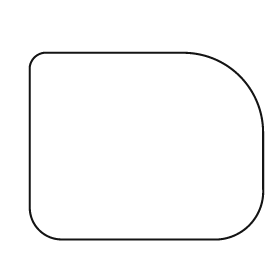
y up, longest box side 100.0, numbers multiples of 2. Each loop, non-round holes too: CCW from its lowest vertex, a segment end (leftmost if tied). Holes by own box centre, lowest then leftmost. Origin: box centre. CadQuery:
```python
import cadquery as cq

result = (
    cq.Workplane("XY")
    .moveTo(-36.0, -40.0)
    .lineTo(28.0, -40.0)
    .threePointArc((44.0, -34.0), (50.0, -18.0))
    .lineTo(50.0, 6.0)
    .threePointArc((40.0, 30.0), (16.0, 40.0))
    .lineTo(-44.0, 40.0)
    .threePointArc((-48.0, 38.0), (-50.0, 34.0))
    .lineTo(-50.0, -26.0)
    .threePointArc((-46.0, -36.0), (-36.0, -40.0))
    .close()
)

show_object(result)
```